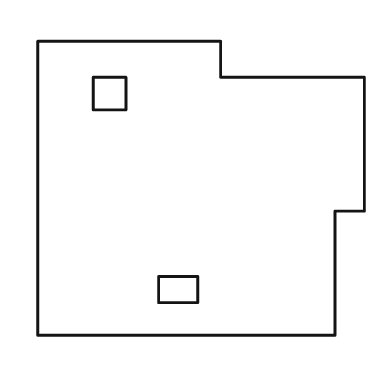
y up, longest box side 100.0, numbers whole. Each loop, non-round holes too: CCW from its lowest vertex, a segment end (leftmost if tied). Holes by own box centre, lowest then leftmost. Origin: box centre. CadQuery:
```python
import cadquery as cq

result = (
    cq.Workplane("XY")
    .moveTo(-50.0, -45.0)
    .lineTo(41.0, -45.0)
    .lineTo(41.0, -7.0)
    .lineTo(50.0, -7.0)
    .lineTo(50.0, 34.0)
    .lineTo(6.0, 34.0)
    .lineTo(6.0, 45.0)
    .lineTo(-50.0, 45.0)
    .close()
    .moveTo(-13.0, -35.0)
    .lineTo(-1.0, -35.0)
    .lineTo(-1.0, -27.0)
    .lineTo(-13.0, -27.0)
    .close()
    .moveTo(-33.0, 24.0)
    .lineTo(-23.0, 24.0)
    .lineTo(-23.0, 34.0)
    .lineTo(-33.0, 34.0)
    .close()
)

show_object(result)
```